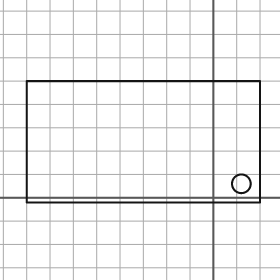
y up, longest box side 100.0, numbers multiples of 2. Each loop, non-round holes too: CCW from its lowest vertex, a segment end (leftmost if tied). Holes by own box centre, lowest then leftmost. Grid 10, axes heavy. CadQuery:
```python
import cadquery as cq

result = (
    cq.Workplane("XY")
    .moveTo(-80.0, -2.0)
    .lineTo(20.0, -2.0)
    .lineTo(20.0, 50.0)
    .lineTo(-80.0, 50.0)
    .close()
    .moveTo(12.0, 6.0)
    .circle(4.0)
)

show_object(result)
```